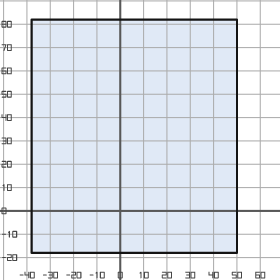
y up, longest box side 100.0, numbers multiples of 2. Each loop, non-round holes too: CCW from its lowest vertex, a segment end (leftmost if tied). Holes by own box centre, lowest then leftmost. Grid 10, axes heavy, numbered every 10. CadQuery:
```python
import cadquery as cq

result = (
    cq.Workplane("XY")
    .moveTo(-38.0, -18.0)
    .lineTo(50.0, -18.0)
    .lineTo(50.0, 82.0)
    .lineTo(-38.0, 82.0)
    .close()
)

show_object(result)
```